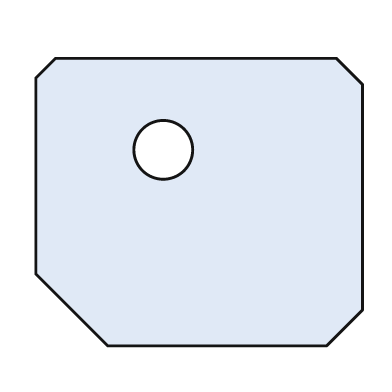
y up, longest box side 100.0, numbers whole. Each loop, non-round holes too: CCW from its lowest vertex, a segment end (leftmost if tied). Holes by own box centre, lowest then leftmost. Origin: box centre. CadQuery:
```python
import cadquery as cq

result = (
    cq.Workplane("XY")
    .moveTo(-28.0, -44.0)
    .lineTo(39.0, -44.0)
    .lineTo(50.0, -33.0)
    .lineTo(50.0, 36.0)
    .lineTo(42.0, 44.0)
    .lineTo(-44.0, 44.0)
    .lineTo(-50.0, 38.0)
    .lineTo(-50.0, -22.0)
    .close()
    .moveTo(-11.0, 16.0)
    .circle(9.0)
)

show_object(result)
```